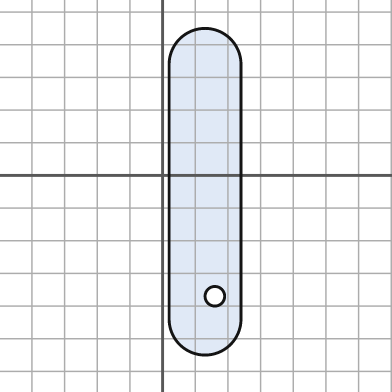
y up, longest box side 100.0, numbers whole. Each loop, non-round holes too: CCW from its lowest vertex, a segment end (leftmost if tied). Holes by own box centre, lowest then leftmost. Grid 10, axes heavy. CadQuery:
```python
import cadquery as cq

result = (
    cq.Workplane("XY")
    .moveTo(2.0, -44.0)
    .threePointArc((13.0, -55.0), (24.0, -44.0))
    .lineTo(24.0, 34.0)
    .threePointArc((13.0, 45.0), (2.0, 34.0))
    .close()
    .moveTo(16.0, -37.0)
    .circle(3.0)
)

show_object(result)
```